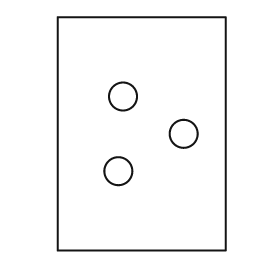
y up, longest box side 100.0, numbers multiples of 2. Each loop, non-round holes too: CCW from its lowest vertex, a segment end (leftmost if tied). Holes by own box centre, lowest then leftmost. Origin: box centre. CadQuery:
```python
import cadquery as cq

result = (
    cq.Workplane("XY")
    .moveTo(-36.0, -50.0)
    .lineTo(36.0, -50.0)
    .lineTo(36.0, 50.0)
    .lineTo(-36.0, 50.0)
    .close()
    .moveTo(-10.0, -16.0)
    .circle(6.0)
    .moveTo(18.0, 0.0)
    .circle(6.0)
    .moveTo(-8.0, 16.0)
    .circle(6.0)
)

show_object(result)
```